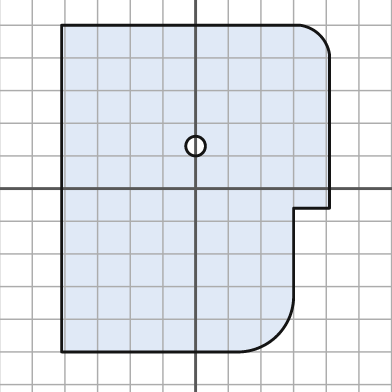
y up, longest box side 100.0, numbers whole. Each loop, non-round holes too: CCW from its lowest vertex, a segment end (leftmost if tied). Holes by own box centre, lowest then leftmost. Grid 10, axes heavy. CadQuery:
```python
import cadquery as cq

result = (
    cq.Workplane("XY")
    .moveTo(-41.0, -50.0)
    .lineTo(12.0, -50.0)
    .threePointArc((25.0, -45.0), (30.0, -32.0))
    .lineTo(30.0, -6.0)
    .lineTo(41.0, -6.0)
    .lineTo(41.0, 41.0)
    .threePointArc((38.0, 47.0), (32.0, 50.0))
    .lineTo(-41.0, 50.0)
    .close()
    .moveTo(0.0, 13.0)
    .circle(3.0)
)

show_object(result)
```